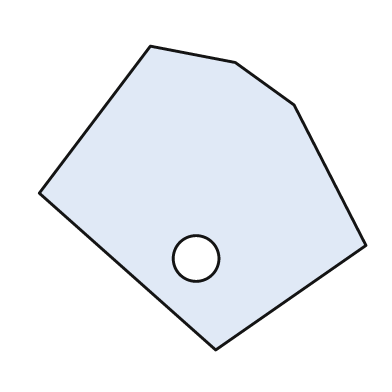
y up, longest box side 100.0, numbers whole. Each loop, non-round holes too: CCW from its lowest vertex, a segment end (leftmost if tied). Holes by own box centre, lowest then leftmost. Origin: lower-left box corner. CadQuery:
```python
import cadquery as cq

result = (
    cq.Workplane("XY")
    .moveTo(54.0, 0.0)
    .lineTo(100.0, 32.0)
    .lineTo(78.0, 75.0)
    .lineTo(60.0, 88.0)
    .lineTo(34.0, 93.0)
    .lineTo(0.0, 48.0)
    .close()
    .moveTo(48.0, 28.0)
    .circle(7.0)
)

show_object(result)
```